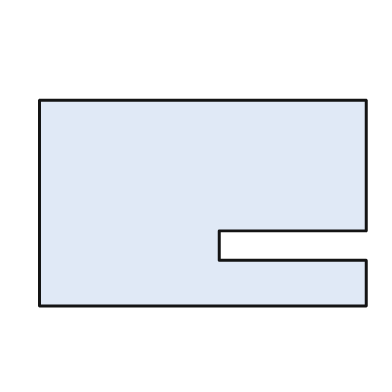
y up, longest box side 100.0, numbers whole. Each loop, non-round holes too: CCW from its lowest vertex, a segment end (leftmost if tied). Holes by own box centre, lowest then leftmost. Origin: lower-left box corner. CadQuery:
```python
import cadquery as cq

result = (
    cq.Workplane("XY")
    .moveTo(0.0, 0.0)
    .lineTo(100.0, 0.0)
    .lineTo(100.0, 14.0)
    .lineTo(55.0, 14.0)
    .lineTo(55.0, 23.0)
    .lineTo(100.0, 23.0)
    .lineTo(100.0, 63.0)
    .lineTo(0.0, 63.0)
    .close()
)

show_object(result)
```